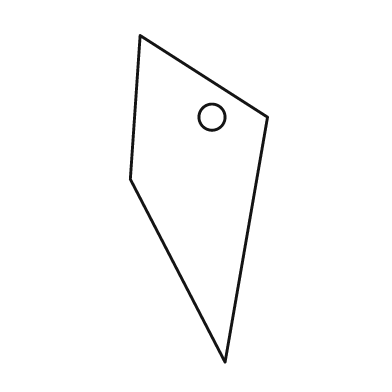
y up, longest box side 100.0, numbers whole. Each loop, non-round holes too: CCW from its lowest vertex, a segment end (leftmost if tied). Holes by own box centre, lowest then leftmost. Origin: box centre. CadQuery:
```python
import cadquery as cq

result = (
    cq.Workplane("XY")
    .moveTo(8.0, -50.0)
    .lineTo(21.0, 25.0)
    .lineTo(-18.0, 50.0)
    .lineTo(-21.0, 6.0)
    .close()
    .moveTo(4.0, 25.0)
    .circle(4.0)
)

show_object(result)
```